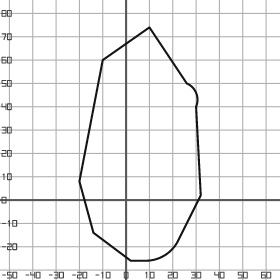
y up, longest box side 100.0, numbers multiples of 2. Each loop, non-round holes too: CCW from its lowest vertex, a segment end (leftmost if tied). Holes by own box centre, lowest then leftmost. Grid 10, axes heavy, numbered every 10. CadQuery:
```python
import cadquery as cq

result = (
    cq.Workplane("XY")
    .moveTo(2.0, -26.0)
    .lineTo(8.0, -26.0)
    .threePointArc((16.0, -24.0), (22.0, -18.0))
    .lineTo(32.0, 2.0)
    .lineTo(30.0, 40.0)
    .threePointArc((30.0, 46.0), (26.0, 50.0))
    .lineTo(10.0, 74.0)
    .lineTo(-10.0, 60.0)
    .lineTo(-20.0, 8.0)
    .lineTo(-14.0, -14.0)
    .close()
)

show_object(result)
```